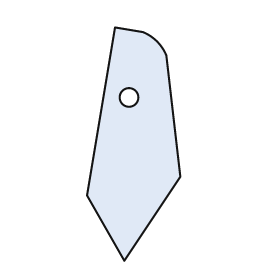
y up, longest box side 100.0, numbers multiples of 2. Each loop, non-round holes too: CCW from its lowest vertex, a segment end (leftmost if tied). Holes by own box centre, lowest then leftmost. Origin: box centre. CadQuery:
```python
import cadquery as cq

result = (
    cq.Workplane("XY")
    .moveTo(-4.0, -50.0)
    .lineTo(20.0, -14.0)
    .lineTo(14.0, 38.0)
    .threePointArc((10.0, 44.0), (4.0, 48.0))
    .lineTo(-8.0, 50.0)
    .lineTo(-20.0, -22.0)
    .close()
    .moveTo(-2.0, 20.0)
    .circle(4.0)
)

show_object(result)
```